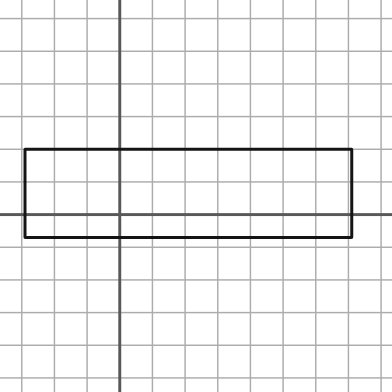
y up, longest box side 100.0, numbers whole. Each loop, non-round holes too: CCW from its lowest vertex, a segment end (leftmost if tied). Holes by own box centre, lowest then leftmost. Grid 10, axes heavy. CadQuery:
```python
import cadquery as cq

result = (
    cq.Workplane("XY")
    .moveTo(-29.0, -7.0)
    .lineTo(71.0, -7.0)
    .lineTo(71.0, 20.0)
    .lineTo(-29.0, 20.0)
    .close()
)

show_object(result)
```